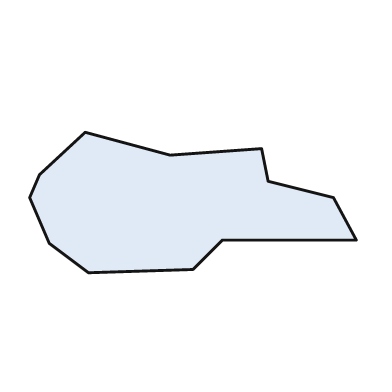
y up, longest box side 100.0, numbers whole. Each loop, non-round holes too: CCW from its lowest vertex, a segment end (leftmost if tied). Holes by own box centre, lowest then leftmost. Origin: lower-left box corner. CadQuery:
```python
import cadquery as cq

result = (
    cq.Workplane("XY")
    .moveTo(18.0, 0.0)
    .lineTo(50.0, 1.0)
    .lineTo(59.0, 10.0)
    .lineTo(100.0, 10.0)
    .lineTo(93.0, 23.0)
    .lineTo(73.0, 28.0)
    .lineTo(71.0, 38.0)
    .lineTo(43.0, 36.0)
    .lineTo(17.0, 43.0)
    .lineTo(3.0, 30.0)
    .lineTo(0.0, 23.0)
    .lineTo(6.0, 9.0)
    .close()
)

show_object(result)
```